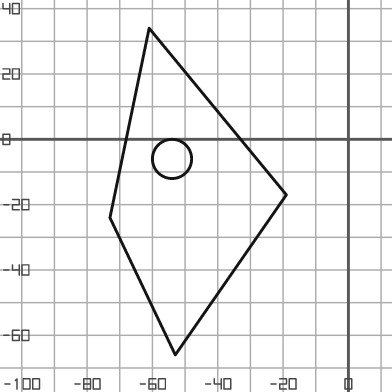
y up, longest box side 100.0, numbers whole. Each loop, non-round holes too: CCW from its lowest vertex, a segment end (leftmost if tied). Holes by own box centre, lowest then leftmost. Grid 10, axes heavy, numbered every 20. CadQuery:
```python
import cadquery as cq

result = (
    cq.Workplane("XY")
    .moveTo(-53.0, -66.0)
    .lineTo(-19.0, -17.0)
    .lineTo(-61.0, 34.0)
    .lineTo(-73.0, -24.0)
    .close()
    .moveTo(-54.0, -6.0)
    .circle(6.0)
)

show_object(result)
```